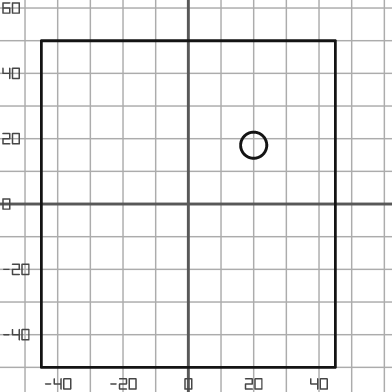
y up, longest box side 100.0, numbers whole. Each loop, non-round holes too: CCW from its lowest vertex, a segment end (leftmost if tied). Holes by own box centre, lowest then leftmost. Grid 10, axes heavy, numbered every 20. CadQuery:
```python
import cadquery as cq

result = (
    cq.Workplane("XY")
    .moveTo(-45.0, -50.0)
    .lineTo(45.0, -50.0)
    .lineTo(45.0, 50.0)
    .lineTo(-45.0, 50.0)
    .close()
    .moveTo(20.0, 18.0)
    .circle(4.0)
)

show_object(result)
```